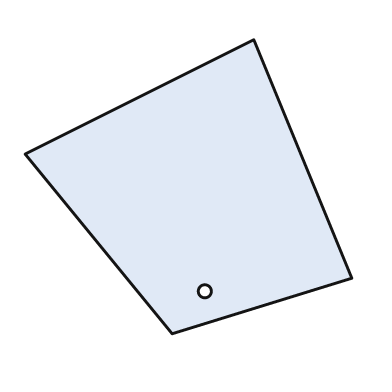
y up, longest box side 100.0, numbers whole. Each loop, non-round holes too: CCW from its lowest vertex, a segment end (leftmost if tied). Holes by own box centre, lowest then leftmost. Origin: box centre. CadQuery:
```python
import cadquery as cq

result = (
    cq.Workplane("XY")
    .moveTo(-5.0, -45.0)
    .lineTo(50.0, -28.0)
    .lineTo(20.0, 45.0)
    .lineTo(-50.0, 10.0)
    .close()
    .moveTo(5.0, -32.0)
    .circle(2.0)
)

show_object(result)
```